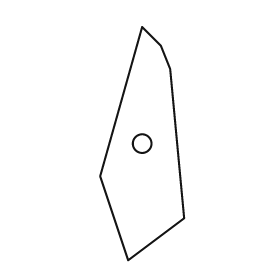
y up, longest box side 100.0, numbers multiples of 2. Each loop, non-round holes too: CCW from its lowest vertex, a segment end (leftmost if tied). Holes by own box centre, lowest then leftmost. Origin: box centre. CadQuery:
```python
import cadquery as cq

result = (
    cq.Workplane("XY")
    .moveTo(-6.0, -50.0)
    .lineTo(18.0, -32.0)
    .lineTo(12.0, 32.0)
    .lineTo(8.0, 42.0)
    .lineTo(0.0, 50.0)
    .lineTo(-18.0, -14.0)
    .close()
    .moveTo(0.0, 0.0)
    .circle(4.0)
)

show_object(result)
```